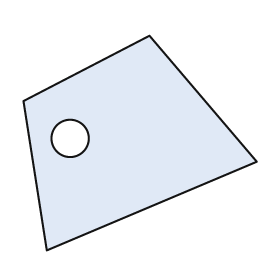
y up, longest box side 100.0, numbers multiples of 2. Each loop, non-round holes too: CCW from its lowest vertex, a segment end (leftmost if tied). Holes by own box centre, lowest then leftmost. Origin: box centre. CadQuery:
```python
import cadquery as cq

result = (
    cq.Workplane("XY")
    .moveTo(-40.0, -46.0)
    .lineTo(50.0, -8.0)
    .lineTo(4.0, 46.0)
    .lineTo(-50.0, 18.0)
    .close()
    .moveTo(-30.0, 2.0)
    .circle(8.0)
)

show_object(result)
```